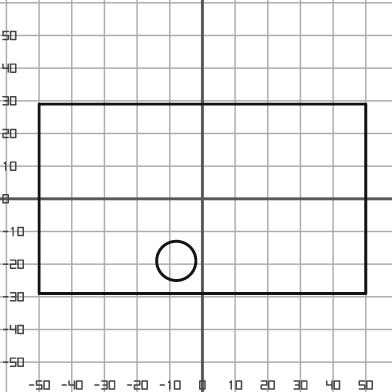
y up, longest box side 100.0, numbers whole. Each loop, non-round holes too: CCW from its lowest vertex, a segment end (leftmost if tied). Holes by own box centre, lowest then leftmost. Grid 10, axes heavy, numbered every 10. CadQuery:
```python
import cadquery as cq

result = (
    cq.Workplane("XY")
    .moveTo(-50.0, -29.0)
    .lineTo(50.0, -29.0)
    .lineTo(50.0, 29.0)
    .lineTo(-50.0, 29.0)
    .close()
    .moveTo(-8.0, -19.0)
    .circle(6.0)
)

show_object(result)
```